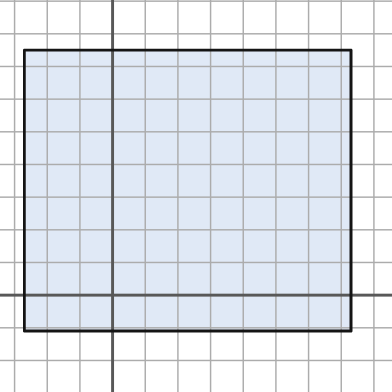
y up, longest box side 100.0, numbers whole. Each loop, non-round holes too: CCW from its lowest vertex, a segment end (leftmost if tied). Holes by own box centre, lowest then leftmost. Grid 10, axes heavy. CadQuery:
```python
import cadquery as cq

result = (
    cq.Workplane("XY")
    .moveTo(-27.0, -11.0)
    .lineTo(73.0, -11.0)
    .lineTo(73.0, 75.0)
    .lineTo(-27.0, 75.0)
    .close()
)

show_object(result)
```